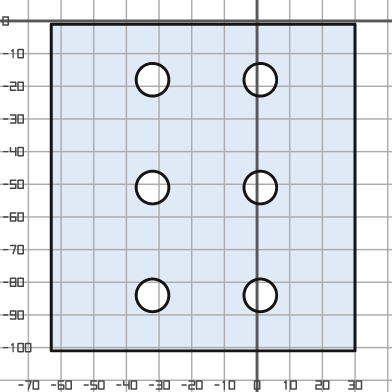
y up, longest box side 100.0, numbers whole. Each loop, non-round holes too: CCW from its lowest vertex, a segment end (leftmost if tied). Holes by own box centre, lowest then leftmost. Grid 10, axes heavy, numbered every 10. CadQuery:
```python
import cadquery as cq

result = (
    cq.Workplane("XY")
    .moveTo(-63.0, -101.0)
    .lineTo(30.0, -101.0)
    .lineTo(30.0, -1.0)
    .lineTo(-63.0, -1.0)
    .close()
    .moveTo(-32.0, -84.0)
    .circle(5.0)
    .moveTo(1.0, -84.0)
    .circle(5.0)
    .moveTo(-32.0, -51.0)
    .circle(5.0)
    .moveTo(1.0, -51.0)
    .circle(5.0)
    .moveTo(-32.0, -18.0)
    .circle(5.0)
    .moveTo(1.0, -18.0)
    .circle(5.0)
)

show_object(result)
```